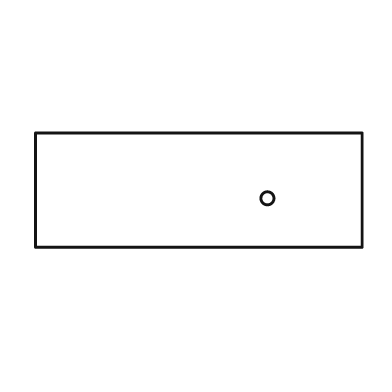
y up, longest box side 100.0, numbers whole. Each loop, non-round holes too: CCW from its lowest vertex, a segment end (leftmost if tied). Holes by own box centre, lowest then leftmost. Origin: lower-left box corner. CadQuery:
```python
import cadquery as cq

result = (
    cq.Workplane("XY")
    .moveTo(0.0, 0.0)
    .lineTo(100.0, 0.0)
    .lineTo(100.0, 35.0)
    .lineTo(0.0, 35.0)
    .close()
    .moveTo(71.0, 15.0)
    .circle(2.0)
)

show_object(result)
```